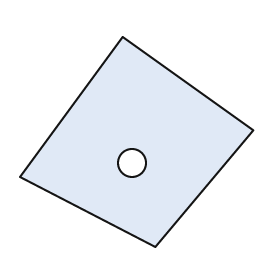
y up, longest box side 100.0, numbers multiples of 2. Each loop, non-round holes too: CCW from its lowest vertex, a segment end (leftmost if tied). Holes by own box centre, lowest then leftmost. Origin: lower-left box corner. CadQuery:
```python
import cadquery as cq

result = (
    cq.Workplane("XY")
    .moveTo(58.0, 0.0)
    .lineTo(100.0, 50.0)
    .lineTo(44.0, 90.0)
    .lineTo(0.0, 30.0)
    .close()
    .moveTo(48.0, 36.0)
    .circle(6.0)
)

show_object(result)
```